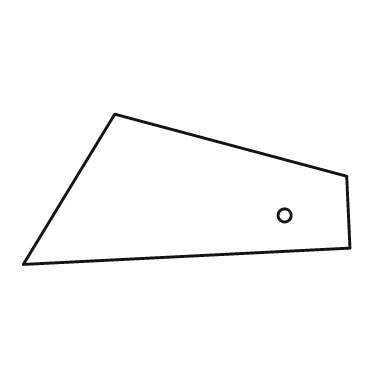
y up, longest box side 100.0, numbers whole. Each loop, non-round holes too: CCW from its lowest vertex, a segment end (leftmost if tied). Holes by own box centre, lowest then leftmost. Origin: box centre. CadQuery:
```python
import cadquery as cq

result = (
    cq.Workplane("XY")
    .moveTo(-50.0, -23.0)
    .lineTo(50.0, -18.0)
    .lineTo(49.0, 4.0)
    .lineTo(-22.0, 23.0)
    .close()
    .moveTo(30.0, -8.0)
    .circle(2.0)
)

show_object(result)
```